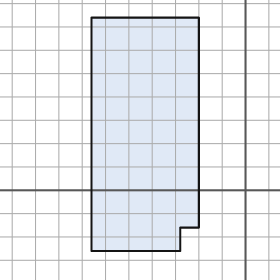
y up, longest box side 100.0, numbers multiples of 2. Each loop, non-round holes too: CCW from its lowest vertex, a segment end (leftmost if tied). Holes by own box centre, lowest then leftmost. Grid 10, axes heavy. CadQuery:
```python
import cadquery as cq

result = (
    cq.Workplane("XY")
    .moveTo(-66.0, -26.0)
    .lineTo(-28.0, -26.0)
    .lineTo(-28.0, -16.0)
    .lineTo(-20.0, -16.0)
    .lineTo(-20.0, 74.0)
    .lineTo(-66.0, 74.0)
    .close()
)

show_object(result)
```